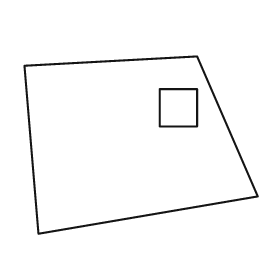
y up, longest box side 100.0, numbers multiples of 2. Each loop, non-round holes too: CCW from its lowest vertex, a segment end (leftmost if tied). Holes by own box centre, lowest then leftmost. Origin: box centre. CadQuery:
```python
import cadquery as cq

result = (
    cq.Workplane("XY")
    .moveTo(-44.0, -38.0)
    .lineTo(50.0, -22.0)
    .lineTo(24.0, 38.0)
    .lineTo(-50.0, 34.0)
    .close()
    .moveTo(8.0, 8.0)
    .lineTo(24.0, 8.0)
    .lineTo(24.0, 24.0)
    .lineTo(8.0, 24.0)
    .close()
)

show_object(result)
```